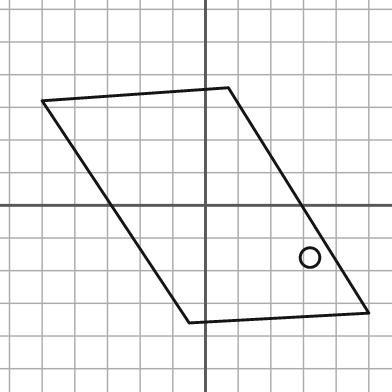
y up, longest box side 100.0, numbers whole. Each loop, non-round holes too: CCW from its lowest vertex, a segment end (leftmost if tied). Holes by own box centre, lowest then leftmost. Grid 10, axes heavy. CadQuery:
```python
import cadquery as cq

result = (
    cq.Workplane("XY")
    .moveTo(-5.0, -36.0)
    .lineTo(50.0, -33.0)
    .lineTo(7.0, 36.0)
    .lineTo(-50.0, 32.0)
    .close()
    .moveTo(32.0, -16.0)
    .circle(3.0)
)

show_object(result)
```